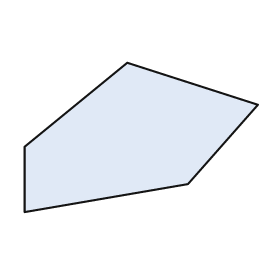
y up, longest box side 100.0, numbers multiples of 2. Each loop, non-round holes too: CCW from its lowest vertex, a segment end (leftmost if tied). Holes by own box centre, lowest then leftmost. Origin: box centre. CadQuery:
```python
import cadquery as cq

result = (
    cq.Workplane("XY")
    .moveTo(-50.0, -32.0)
    .lineTo(20.0, -20.0)
    .lineTo(50.0, 14.0)
    .lineTo(-6.0, 32.0)
    .lineTo(-50.0, -4.0)
    .close()
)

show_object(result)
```